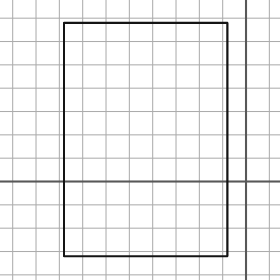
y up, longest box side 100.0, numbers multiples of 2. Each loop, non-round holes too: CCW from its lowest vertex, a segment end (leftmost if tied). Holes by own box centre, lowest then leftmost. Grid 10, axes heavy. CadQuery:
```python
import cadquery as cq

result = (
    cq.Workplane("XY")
    .moveTo(-78.0, -32.0)
    .lineTo(-8.0, -32.0)
    .lineTo(-8.0, 68.0)
    .lineTo(-78.0, 68.0)
    .close()
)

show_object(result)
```